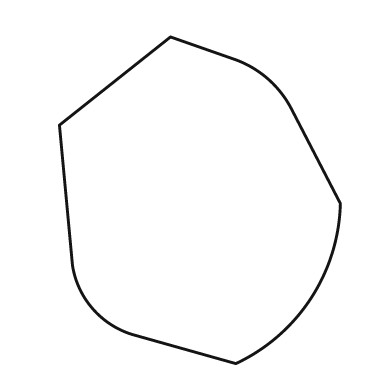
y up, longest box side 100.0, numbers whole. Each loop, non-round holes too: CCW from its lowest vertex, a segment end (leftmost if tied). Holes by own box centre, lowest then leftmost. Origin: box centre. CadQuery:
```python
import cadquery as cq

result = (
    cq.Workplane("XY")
    .moveTo(11.0, -50.0)
    .threePointArc((34.0, -30.0), (43.0, -1.0))
    .lineTo(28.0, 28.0)
    .threePointArc((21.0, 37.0), (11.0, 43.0))
    .lineTo(-9.0, 50.0)
    .lineTo(-43.0, 23.0)
    .lineTo(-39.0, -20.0)
    .threePointArc((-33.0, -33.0), (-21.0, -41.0))
    .close()
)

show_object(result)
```